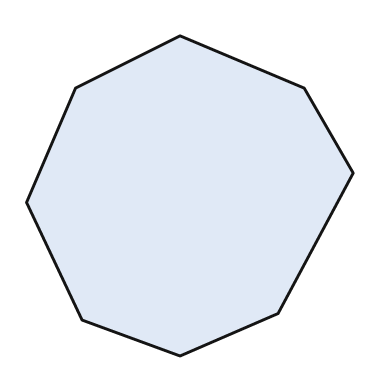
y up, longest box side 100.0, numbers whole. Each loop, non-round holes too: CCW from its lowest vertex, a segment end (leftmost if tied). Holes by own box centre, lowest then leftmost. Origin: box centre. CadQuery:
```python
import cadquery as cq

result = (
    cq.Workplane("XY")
    .moveTo(-3.0, -49.0)
    .lineTo(27.0, -36.0)
    .lineTo(50.0, 7.0)
    .lineTo(35.0, 33.0)
    .lineTo(-3.0, 49.0)
    .lineTo(-35.0, 33.0)
    .lineTo(-50.0, -2.0)
    .lineTo(-33.0, -38.0)
    .close()
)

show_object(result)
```